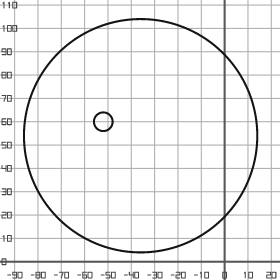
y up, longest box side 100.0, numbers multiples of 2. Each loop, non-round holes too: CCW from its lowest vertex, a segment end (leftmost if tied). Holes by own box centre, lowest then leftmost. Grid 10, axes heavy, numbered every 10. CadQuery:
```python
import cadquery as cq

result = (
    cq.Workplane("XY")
    .moveTo(-36.0, 54.0)
    .circle(50.0)
    .moveTo(-52.0, 60.0)
    .circle(4.0)
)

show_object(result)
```